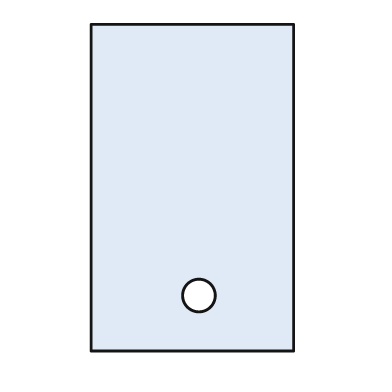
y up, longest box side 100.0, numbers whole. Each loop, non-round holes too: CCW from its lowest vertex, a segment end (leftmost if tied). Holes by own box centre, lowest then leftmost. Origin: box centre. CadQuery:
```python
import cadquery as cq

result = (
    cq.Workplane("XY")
    .moveTo(-31.0, -50.0)
    .lineTo(31.0, -50.0)
    .lineTo(31.0, 50.0)
    .lineTo(-31.0, 50.0)
    .close()
    .moveTo(2.0, -33.0)
    .circle(5.0)
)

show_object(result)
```